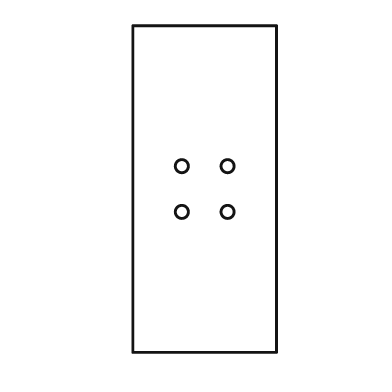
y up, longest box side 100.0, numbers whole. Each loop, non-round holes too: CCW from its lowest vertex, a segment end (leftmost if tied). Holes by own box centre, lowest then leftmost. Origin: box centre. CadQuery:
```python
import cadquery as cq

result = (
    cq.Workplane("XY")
    .moveTo(-22.0, -50.0)
    .lineTo(22.0, -50.0)
    .lineTo(22.0, 50.0)
    .lineTo(-22.0, 50.0)
    .close()
    .moveTo(-7.0, -7.0)
    .circle(2.0)
    .moveTo(7.0, -7.0)
    .circle(2.0)
    .moveTo(-7.0, 7.0)
    .circle(2.0)
    .moveTo(7.0, 7.0)
    .circle(2.0)
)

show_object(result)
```